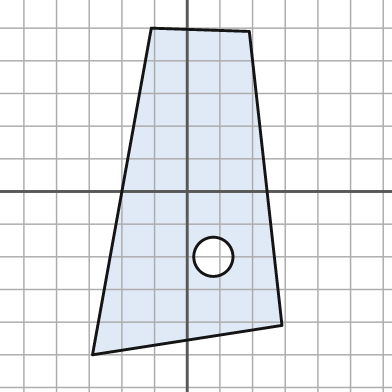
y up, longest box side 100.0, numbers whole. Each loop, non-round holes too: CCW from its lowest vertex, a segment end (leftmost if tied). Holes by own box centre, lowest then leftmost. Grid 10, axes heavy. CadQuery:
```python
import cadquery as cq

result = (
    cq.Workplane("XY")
    .moveTo(-29.0, -50.0)
    .lineTo(29.0, -41.0)
    .lineTo(19.0, 49.0)
    .lineTo(-11.0, 50.0)
    .close()
    .moveTo(8.0, -20.0)
    .circle(6.0)
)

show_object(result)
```